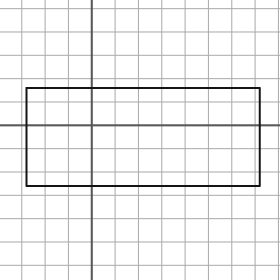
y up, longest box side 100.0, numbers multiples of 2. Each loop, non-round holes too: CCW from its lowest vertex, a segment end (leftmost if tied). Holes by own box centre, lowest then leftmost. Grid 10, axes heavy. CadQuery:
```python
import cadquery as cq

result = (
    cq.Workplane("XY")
    .moveTo(-28.0, -26.0)
    .lineTo(72.0, -26.0)
    .lineTo(72.0, 16.0)
    .lineTo(-28.0, 16.0)
    .close()
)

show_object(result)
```